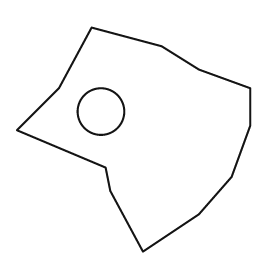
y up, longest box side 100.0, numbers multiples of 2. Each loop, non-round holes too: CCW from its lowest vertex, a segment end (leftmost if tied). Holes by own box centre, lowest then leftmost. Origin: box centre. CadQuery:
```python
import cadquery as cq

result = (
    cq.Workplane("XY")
    .moveTo(4.0, -48.0)
    .lineTo(28.0, -32.0)
    .lineTo(42.0, -16.0)
    .lineTo(50.0, 6.0)
    .lineTo(50.0, 22.0)
    .lineTo(28.0, 30.0)
    .lineTo(12.0, 40.0)
    .lineTo(-18.0, 48.0)
    .lineTo(-32.0, 22.0)
    .lineTo(-50.0, 4.0)
    .lineTo(-12.0, -12.0)
    .lineTo(-10.0, -22.0)
    .close()
    .moveTo(-14.0, 12.0)
    .circle(10.0)
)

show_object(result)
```